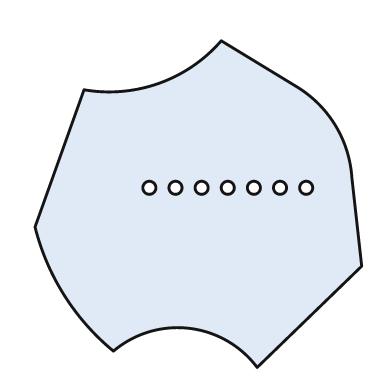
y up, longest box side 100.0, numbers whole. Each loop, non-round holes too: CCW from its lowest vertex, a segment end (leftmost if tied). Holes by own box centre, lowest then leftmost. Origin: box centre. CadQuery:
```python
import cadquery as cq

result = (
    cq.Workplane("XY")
    .moveTo(18.0, -50.0)
    .lineTo(50.0, -19.0)
    .lineTo(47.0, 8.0)
    .threePointArc((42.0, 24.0), (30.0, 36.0))
    .lineTo(7.0, 50.0)
    .threePointArc((-12.0, 37.0), (-35.0, 35.0))
    .lineTo(-50.0, -7.0)
    .threePointArc((-41.0, -28.0), (-26.0, -45.0))
    .threePointArc((-3.0, -38.0), (18.0, -50.0))
    .close()
    .moveTo(-15.0, 5.0)
    .circle(2.0)
    .moveTo(-7.0, 5.0)
    .circle(2.0)
    .moveTo(1.0, 5.0)
    .circle(2.0)
    .moveTo(9.0, 5.0)
    .circle(2.0)
    .moveTo(17.0, 5.0)
    .circle(2.0)
    .moveTo(25.0, 5.0)
    .circle(2.0)
    .moveTo(33.0, 5.0)
    .circle(2.0)
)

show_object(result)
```